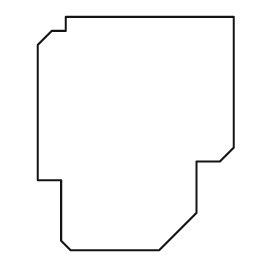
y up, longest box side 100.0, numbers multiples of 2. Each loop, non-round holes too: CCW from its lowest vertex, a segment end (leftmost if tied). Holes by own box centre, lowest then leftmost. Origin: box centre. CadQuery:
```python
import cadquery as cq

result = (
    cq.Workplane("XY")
    .moveTo(-28.0, -50.0)
    .lineTo(10.0, -50.0)
    .lineTo(26.0, -34.0)
    .lineTo(26.0, -12.0)
    .lineTo(36.0, -12.0)
    .lineTo(42.0, -6.0)
    .lineTo(42.0, 50.0)
    .lineTo(-30.0, 50.0)
    .lineTo(-30.0, 44.0)
    .lineTo(-36.0, 44.0)
    .lineTo(-42.0, 38.0)
    .lineTo(-42.0, -20.0)
    .lineTo(-32.0, -20.0)
    .lineTo(-32.0, -46.0)
    .close()
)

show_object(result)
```